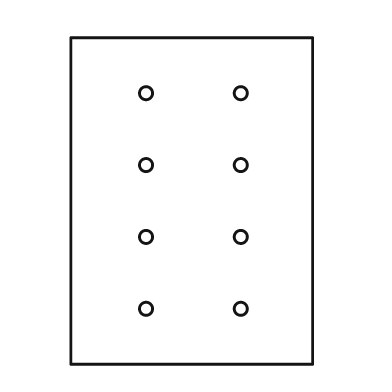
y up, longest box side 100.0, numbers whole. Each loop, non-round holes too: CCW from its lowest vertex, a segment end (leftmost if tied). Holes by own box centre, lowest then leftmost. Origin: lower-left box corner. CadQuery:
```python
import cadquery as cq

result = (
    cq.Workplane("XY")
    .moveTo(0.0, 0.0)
    .lineTo(74.0, 0.0)
    .lineTo(74.0, 100.0)
    .lineTo(0.0, 100.0)
    .close()
    .moveTo(23.0, 17.0)
    .circle(2.0)
    .moveTo(52.0, 17.0)
    .circle(2.0)
    .moveTo(23.0, 39.0)
    .circle(2.0)
    .moveTo(52.0, 39.0)
    .circle(2.0)
    .moveTo(23.0, 61.0)
    .circle(2.0)
    .moveTo(52.0, 61.0)
    .circle(2.0)
    .moveTo(23.0, 83.0)
    .circle(2.0)
    .moveTo(52.0, 83.0)
    .circle(2.0)
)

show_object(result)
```